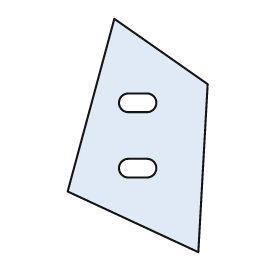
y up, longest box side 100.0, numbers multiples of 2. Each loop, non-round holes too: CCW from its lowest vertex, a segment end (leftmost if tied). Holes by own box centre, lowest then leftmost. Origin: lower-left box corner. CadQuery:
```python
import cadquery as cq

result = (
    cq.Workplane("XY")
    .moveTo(56.0, 0.0)
    .lineTo(60.0, 72.0)
    .lineTo(20.0, 100.0)
    .lineTo(0.0, 26.0)
    .close()
    .moveTo(26.0, 32.0)
    .lineTo(34.0, 32.0)
    .threePointArc((38.0, 36.0), (34.0, 40.0))
    .lineTo(26.0, 40.0)
    .threePointArc((22.0, 36.0), (26.0, 32.0))
    .close()
    .moveTo(26.0, 60.0)
    .lineTo(34.0, 60.0)
    .threePointArc((38.0, 64.0), (34.0, 68.0))
    .lineTo(26.0, 68.0)
    .threePointArc((22.0, 64.0), (26.0, 60.0))
    .close()
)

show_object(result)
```